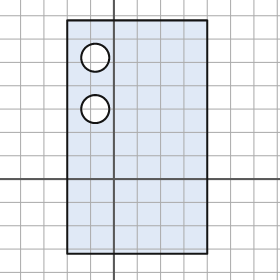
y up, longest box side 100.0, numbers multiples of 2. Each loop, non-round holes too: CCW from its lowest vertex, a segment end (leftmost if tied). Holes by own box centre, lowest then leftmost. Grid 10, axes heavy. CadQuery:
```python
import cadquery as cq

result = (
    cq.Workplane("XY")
    .moveTo(-20.0, -32.0)
    .lineTo(40.0, -32.0)
    .lineTo(40.0, 68.0)
    .lineTo(-20.0, 68.0)
    .close()
    .moveTo(-8.0, 30.0)
    .circle(6.0)
    .moveTo(-8.0, 52.0)
    .circle(6.0)
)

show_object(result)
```